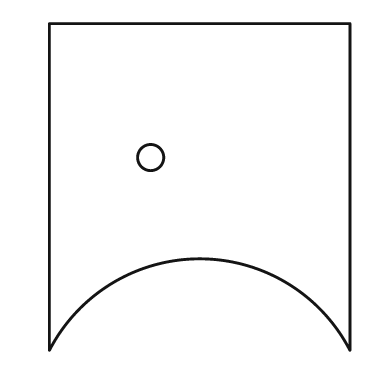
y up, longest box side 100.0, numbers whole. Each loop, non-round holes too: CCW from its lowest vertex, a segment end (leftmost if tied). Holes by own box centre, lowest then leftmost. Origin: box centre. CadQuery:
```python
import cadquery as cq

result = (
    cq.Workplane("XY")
    .moveTo(-46.0, -50.0)
    .threePointArc((0.0, -22.0), (46.0, -50.0))
    .lineTo(46.0, 50.0)
    .lineTo(-46.0, 50.0)
    .close()
    .moveTo(-15.0, 9.0)
    .circle(4.0)
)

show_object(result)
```